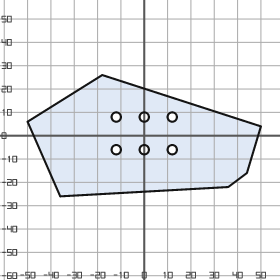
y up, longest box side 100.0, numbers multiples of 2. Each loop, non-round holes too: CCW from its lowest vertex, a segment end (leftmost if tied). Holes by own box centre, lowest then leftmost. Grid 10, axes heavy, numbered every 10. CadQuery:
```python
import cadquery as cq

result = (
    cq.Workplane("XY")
    .moveTo(-36.0, -26.0)
    .lineTo(36.0, -22.0)
    .lineTo(44.0, -16.0)
    .lineTo(50.0, 4.0)
    .lineTo(-18.0, 26.0)
    .lineTo(-50.0, 6.0)
    .close()
    .moveTo(-12.0, -6.0)
    .circle(2.0)
    .moveTo(0.0, -6.0)
    .circle(2.0)
    .moveTo(12.0, -6.0)
    .circle(2.0)
    .moveTo(-12.0, 8.0)
    .circle(2.0)
    .moveTo(0.0, 8.0)
    .circle(2.0)
    .moveTo(12.0, 8.0)
    .circle(2.0)
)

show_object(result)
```